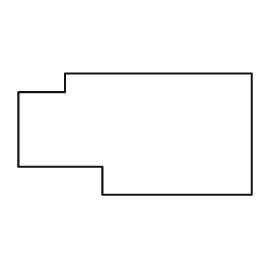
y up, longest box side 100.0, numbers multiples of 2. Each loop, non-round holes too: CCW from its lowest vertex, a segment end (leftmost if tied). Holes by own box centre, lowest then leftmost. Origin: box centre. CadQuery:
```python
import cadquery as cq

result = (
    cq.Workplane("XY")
    .moveTo(-14.0, -26.0)
    .lineTo(50.0, -26.0)
    .lineTo(50.0, 26.0)
    .lineTo(-30.0, 26.0)
    .lineTo(-30.0, 18.0)
    .lineTo(-50.0, 18.0)
    .lineTo(-50.0, -14.0)
    .lineTo(-14.0, -14.0)
    .close()
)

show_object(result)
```